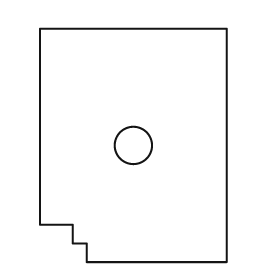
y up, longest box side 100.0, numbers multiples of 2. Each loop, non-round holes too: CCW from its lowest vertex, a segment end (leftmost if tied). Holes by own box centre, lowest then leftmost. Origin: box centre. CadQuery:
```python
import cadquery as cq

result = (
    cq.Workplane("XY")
    .moveTo(-20.0, -50.0)
    .lineTo(40.0, -50.0)
    .lineTo(40.0, 50.0)
    .lineTo(-40.0, 50.0)
    .lineTo(-40.0, -34.0)
    .lineTo(-26.0, -34.0)
    .lineTo(-26.0, -42.0)
    .lineTo(-20.0, -42.0)
    .close()
    .moveTo(0.0, 0.0)
    .circle(8.0)
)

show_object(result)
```